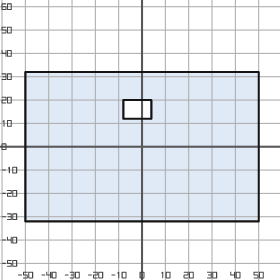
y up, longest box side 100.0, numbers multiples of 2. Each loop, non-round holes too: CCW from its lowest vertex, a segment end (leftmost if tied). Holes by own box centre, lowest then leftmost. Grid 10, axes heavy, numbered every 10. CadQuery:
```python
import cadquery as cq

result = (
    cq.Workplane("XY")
    .moveTo(-50.0, -32.0)
    .lineTo(50.0, -32.0)
    .lineTo(50.0, 32.0)
    .lineTo(-50.0, 32.0)
    .close()
    .moveTo(-8.0, 12.0)
    .lineTo(4.0, 12.0)
    .lineTo(4.0, 20.0)
    .lineTo(-8.0, 20.0)
    .close()
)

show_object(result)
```